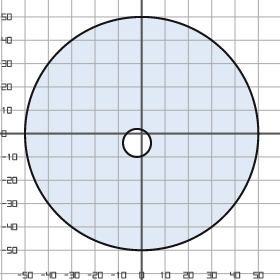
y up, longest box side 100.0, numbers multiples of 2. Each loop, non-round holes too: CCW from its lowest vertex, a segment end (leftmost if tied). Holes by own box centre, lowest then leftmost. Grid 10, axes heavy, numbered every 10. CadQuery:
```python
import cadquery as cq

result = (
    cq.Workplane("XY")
    .moveTo(0.0, 0.0)
    .circle(50.0)
    .moveTo(-2.0, -4.0)
    .circle(6.0)
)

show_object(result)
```